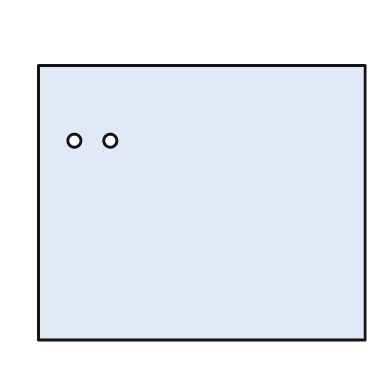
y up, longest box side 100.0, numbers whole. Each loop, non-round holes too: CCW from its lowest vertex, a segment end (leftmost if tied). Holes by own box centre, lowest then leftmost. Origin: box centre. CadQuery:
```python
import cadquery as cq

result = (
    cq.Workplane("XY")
    .moveTo(-50.0, -42.0)
    .lineTo(50.0, -42.0)
    .lineTo(50.0, 42.0)
    .lineTo(-50.0, 42.0)
    .close()
    .moveTo(-39.0, 19.0)
    .circle(2.0)
    .moveTo(-28.0, 19.0)
    .circle(2.0)
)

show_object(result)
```